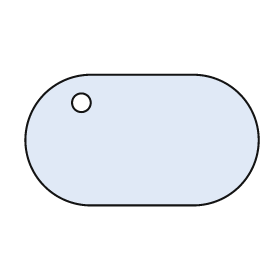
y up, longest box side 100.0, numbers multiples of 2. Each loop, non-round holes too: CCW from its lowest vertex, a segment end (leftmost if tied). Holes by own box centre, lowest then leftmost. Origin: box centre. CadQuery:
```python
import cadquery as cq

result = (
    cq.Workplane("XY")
    .moveTo(-22.0, -28.0)
    .lineTo(22.0, -28.0)
    .threePointArc((50.0, 0.0), (22.0, 28.0))
    .lineTo(-22.0, 28.0)
    .threePointArc((-50.0, 0.0), (-22.0, -28.0))
    .close()
    .moveTo(-26.0, 16.0)
    .circle(4.0)
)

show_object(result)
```